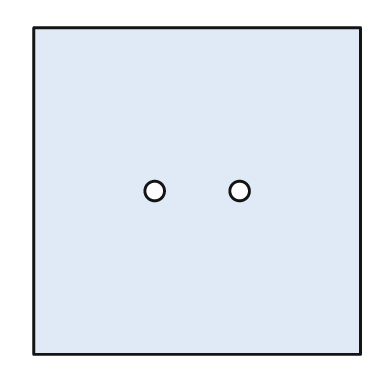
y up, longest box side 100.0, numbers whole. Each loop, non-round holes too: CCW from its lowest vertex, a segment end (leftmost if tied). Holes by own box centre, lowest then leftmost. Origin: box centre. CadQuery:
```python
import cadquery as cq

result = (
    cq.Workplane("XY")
    .moveTo(-50.0, -50.0)
    .lineTo(50.0, -50.0)
    .lineTo(50.0, 50.0)
    .lineTo(-50.0, 50.0)
    .close()
    .moveTo(-13.0, 0.0)
    .circle(3.0)
    .moveTo(13.0, 0.0)
    .circle(3.0)
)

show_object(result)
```